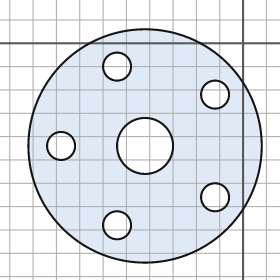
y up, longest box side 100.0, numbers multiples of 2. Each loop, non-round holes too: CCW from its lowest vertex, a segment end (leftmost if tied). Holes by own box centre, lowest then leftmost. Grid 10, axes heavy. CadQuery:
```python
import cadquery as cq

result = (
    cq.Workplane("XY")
    .moveTo(-42.0, -44.0)
    .circle(50.0)
    .moveTo(-54.0, -78.0)
    .circle(6.0)
    .moveTo(-12.0, -66.0)
    .circle(6.0)
    .moveTo(-78.0, -44.0)
    .circle(6.0)
    .moveTo(-42.0, -44.0)
    .circle(12.0)
    .moveTo(-12.0, -22.0)
    .circle(6.0)
    .moveTo(-54.0, -10.0)
    .circle(6.0)
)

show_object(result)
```